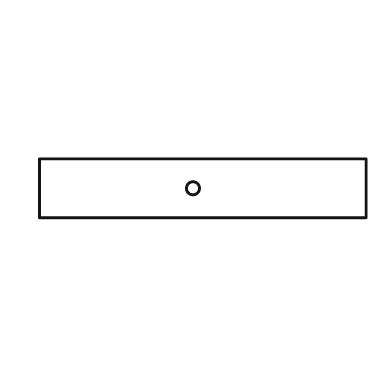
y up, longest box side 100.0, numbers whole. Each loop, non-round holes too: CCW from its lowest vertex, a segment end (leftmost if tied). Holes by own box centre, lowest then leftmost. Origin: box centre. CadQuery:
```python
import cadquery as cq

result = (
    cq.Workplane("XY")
    .moveTo(-50.0, -9.0)
    .lineTo(50.0, -9.0)
    .lineTo(50.0, 9.0)
    .lineTo(-50.0, 9.0)
    .close()
    .moveTo(-3.0, 0.0)
    .circle(2.0)
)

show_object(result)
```